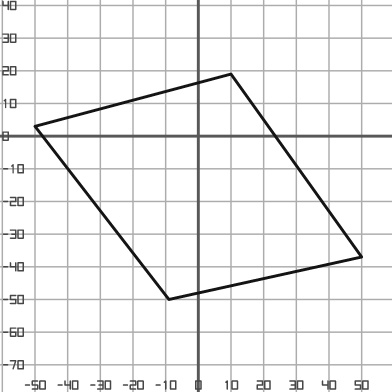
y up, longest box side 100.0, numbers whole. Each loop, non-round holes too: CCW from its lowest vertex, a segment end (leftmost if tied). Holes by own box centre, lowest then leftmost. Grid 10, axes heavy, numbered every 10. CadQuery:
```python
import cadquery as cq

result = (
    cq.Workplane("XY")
    .moveTo(-9.0, -50.0)
    .lineTo(50.0, -37.0)
    .lineTo(10.0, 19.0)
    .lineTo(-50.0, 3.0)
    .close()
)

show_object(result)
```